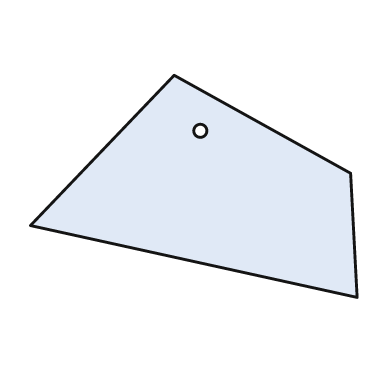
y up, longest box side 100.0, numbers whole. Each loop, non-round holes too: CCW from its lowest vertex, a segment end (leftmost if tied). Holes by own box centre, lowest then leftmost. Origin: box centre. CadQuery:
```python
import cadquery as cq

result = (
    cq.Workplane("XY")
    .moveTo(50.0, -34.0)
    .lineTo(48.0, 4.0)
    .lineTo(-6.0, 34.0)
    .lineTo(-50.0, -12.0)
    .close()
    .moveTo(2.0, 17.0)
    .circle(2.0)
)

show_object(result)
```